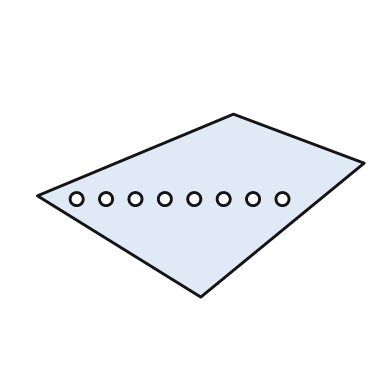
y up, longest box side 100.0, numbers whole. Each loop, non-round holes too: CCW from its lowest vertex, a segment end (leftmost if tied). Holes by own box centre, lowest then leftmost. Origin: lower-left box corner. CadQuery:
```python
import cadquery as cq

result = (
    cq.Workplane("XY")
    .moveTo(50.0, 0.0)
    .lineTo(100.0, 41.0)
    .lineTo(60.0, 56.0)
    .lineTo(0.0, 31.0)
    .close()
    .moveTo(12.0, 30.0)
    .circle(2.0)
    .moveTo(21.0, 30.0)
    .circle(2.0)
    .moveTo(30.0, 30.0)
    .circle(2.0)
    .moveTo(39.0, 30.0)
    .circle(2.0)
    .moveTo(48.0, 30.0)
    .circle(2.0)
    .moveTo(57.0, 30.0)
    .circle(2.0)
    .moveTo(66.0, 30.0)
    .circle(2.0)
    .moveTo(75.0, 30.0)
    .circle(2.0)
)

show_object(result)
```